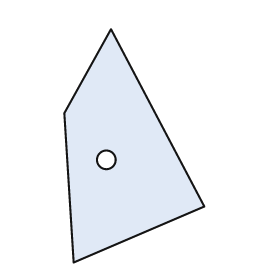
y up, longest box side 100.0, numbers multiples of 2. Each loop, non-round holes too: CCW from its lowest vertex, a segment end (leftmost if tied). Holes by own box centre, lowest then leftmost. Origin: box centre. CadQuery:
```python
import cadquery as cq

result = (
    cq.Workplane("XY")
    .moveTo(-26.0, -50.0)
    .lineTo(30.0, -26.0)
    .lineTo(-10.0, 50.0)
    .lineTo(-30.0, 14.0)
    .close()
    .moveTo(-12.0, -6.0)
    .circle(4.0)
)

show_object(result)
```